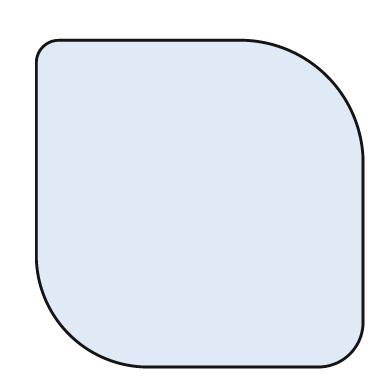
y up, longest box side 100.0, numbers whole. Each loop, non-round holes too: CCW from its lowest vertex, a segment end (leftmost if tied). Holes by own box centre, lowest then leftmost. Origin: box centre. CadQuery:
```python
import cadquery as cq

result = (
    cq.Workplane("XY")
    .moveTo(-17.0, -50.0)
    .lineTo(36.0, -50.0)
    .threePointArc((46.0, -46.0), (50.0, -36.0))
    .lineTo(50.0, 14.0)
    .threePointArc((39.0, 39.0), (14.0, 50.0))
    .lineTo(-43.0, 50.0)
    .threePointArc((-48.0, 48.0), (-50.0, 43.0))
    .lineTo(-50.0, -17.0)
    .threePointArc((-40.0, -40.0), (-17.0, -50.0))
    .close()
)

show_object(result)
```